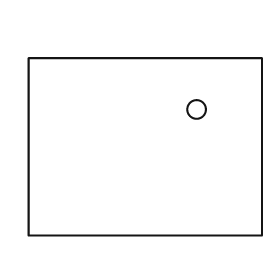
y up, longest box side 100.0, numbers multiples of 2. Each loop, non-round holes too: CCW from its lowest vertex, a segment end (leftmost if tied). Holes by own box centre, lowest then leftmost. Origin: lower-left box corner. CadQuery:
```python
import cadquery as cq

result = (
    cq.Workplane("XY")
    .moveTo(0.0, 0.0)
    .lineTo(100.0, 0.0)
    .lineTo(100.0, 76.0)
    .lineTo(0.0, 76.0)
    .close()
    .moveTo(72.0, 54.0)
    .circle(4.0)
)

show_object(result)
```